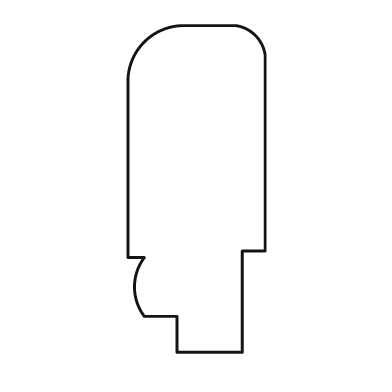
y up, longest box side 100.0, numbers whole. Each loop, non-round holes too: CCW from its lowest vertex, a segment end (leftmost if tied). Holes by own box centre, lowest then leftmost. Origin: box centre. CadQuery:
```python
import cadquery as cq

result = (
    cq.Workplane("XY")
    .moveTo(-6.0, -50.0)
    .lineTo(14.0, -50.0)
    .lineTo(14.0, -19.0)
    .lineTo(21.0, -19.0)
    .lineTo(21.0, 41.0)
    .threePointArc((18.0, 47.0), (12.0, 50.0))
    .lineTo(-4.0, 50.0)
    .threePointArc((-16.0, 45.0), (-21.0, 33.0))
    .lineTo(-21.0, -21.0)
    .lineTo(-16.0, -21.0)
    .threePointArc((-19.0, -30.0), (-16.0, -39.0))
    .lineTo(-6.0, -39.0)
    .close()
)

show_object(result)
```